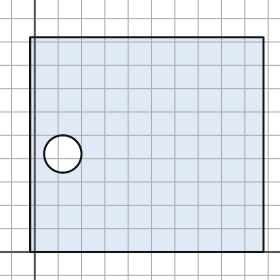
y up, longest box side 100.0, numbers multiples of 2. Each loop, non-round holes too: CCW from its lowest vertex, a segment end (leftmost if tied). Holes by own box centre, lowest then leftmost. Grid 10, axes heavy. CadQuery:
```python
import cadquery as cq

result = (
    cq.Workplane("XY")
    .moveTo(-2.0, 0.0)
    .lineTo(98.0, 0.0)
    .lineTo(98.0, 92.0)
    .lineTo(-2.0, 92.0)
    .close()
    .moveTo(12.0, 42.0)
    .circle(8.0)
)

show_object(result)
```